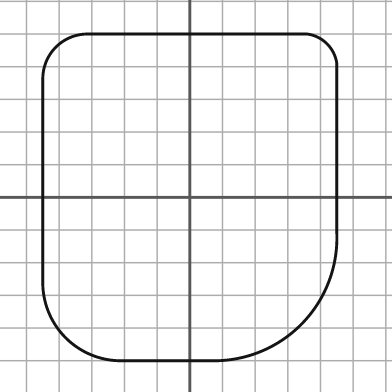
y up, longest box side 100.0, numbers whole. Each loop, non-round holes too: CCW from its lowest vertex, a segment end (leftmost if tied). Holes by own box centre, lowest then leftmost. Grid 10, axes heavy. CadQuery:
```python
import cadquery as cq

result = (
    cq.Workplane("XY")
    .moveTo(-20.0, -50.0)
    .lineTo(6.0, -50.0)
    .threePointArc((34.0, -39.0), (45.0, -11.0))
    .lineTo(45.0, 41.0)
    .threePointArc((42.0, 47.0), (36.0, 50.0))
    .lineTo(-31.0, 50.0)
    .threePointArc((-41.0, 46.0), (-45.0, 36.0))
    .lineTo(-45.0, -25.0)
    .threePointArc((-38.0, -43.0), (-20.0, -50.0))
    .close()
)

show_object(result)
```